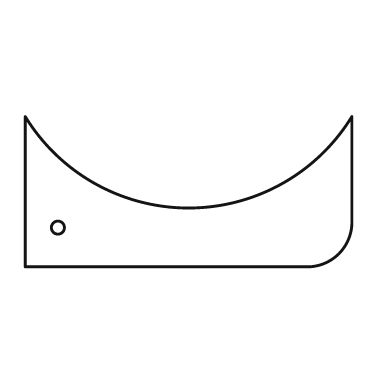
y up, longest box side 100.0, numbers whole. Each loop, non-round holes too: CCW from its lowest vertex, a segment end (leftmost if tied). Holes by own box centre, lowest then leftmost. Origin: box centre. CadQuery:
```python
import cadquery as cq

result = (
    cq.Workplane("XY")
    .moveTo(-50.0, -23.0)
    .lineTo(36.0, -23.0)
    .threePointArc((46.0, -19.0), (50.0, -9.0))
    .lineTo(50.0, 23.0)
    .threePointArc((0.0, -5.0), (-50.0, 23.0))
    .close()
    .moveTo(-40.0, -11.0)
    .circle(2.0)
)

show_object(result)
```